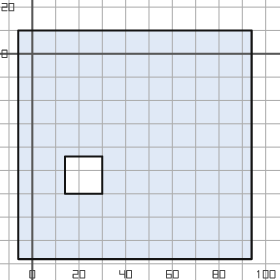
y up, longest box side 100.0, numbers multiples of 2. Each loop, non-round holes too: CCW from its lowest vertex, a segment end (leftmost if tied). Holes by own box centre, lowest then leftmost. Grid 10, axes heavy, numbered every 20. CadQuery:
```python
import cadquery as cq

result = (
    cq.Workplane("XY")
    .moveTo(-6.0, -88.0)
    .lineTo(94.0, -88.0)
    .lineTo(94.0, 10.0)
    .lineTo(-6.0, 10.0)
    .close()
    .moveTo(14.0, -60.0)
    .lineTo(30.0, -60.0)
    .lineTo(30.0, -44.0)
    .lineTo(14.0, -44.0)
    .close()
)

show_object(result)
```